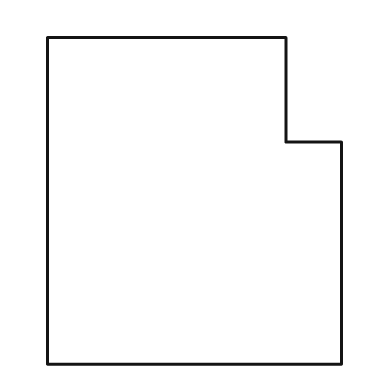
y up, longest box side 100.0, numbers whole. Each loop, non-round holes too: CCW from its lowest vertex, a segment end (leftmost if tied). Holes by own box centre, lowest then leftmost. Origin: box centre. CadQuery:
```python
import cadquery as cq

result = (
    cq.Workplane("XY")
    .moveTo(-45.0, -50.0)
    .lineTo(45.0, -50.0)
    .lineTo(45.0, 18.0)
    .lineTo(28.0, 18.0)
    .lineTo(28.0, 50.0)
    .lineTo(-45.0, 50.0)
    .close()
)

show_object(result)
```